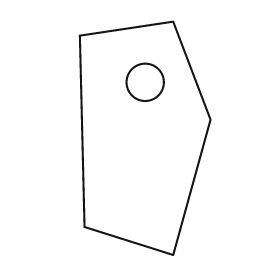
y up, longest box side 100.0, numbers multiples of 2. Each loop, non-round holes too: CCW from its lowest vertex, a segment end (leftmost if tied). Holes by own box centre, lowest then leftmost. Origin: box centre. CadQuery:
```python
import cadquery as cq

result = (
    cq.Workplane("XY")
    .moveTo(12.0, -50.0)
    .lineTo(28.0, 8.0)
    .lineTo(12.0, 50.0)
    .lineTo(-28.0, 44.0)
    .lineTo(-26.0, -38.0)
    .close()
    .moveTo(0.0, 24.0)
    .circle(8.0)
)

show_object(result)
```